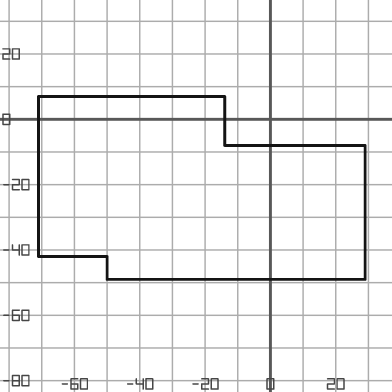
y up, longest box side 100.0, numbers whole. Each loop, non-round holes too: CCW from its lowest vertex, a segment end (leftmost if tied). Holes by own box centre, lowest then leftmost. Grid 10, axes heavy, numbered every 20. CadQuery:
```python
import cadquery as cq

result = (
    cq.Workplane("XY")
    .moveTo(-50.0, -49.0)
    .lineTo(29.0, -49.0)
    .lineTo(29.0, -8.0)
    .lineTo(-14.0, -8.0)
    .lineTo(-14.0, 7.0)
    .lineTo(-71.0, 7.0)
    .lineTo(-71.0, -42.0)
    .lineTo(-50.0, -42.0)
    .close()
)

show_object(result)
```